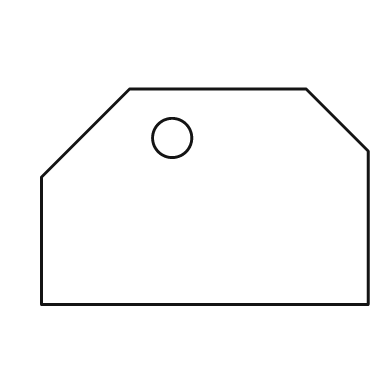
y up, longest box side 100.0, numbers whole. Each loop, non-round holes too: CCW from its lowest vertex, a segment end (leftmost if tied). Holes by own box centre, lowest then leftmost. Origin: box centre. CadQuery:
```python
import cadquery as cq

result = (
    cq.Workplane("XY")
    .moveTo(-50.0, -33.0)
    .lineTo(50.0, -33.0)
    .lineTo(50.0, 14.0)
    .lineTo(31.0, 33.0)
    .lineTo(-23.0, 33.0)
    .lineTo(-50.0, 6.0)
    .close()
    .moveTo(-10.0, 18.0)
    .circle(6.0)
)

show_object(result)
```